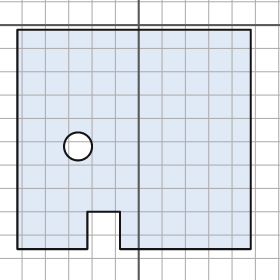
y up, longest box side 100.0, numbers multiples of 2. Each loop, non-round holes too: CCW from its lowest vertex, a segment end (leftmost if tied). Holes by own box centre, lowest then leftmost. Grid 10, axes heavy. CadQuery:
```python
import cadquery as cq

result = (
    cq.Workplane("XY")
    .moveTo(-52.0, -96.0)
    .lineTo(-22.0, -96.0)
    .lineTo(-22.0, -80.0)
    .lineTo(-8.0, -80.0)
    .lineTo(-8.0, -96.0)
    .lineTo(48.0, -96.0)
    .lineTo(48.0, -2.0)
    .lineTo(-52.0, -2.0)
    .close()
    .moveTo(-26.0, -52.0)
    .circle(6.0)
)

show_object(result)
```